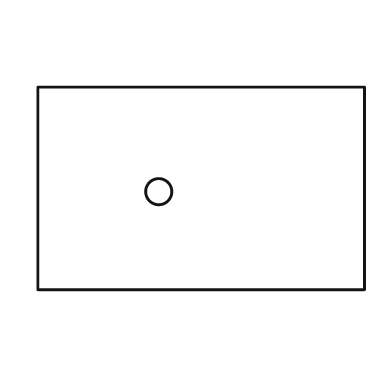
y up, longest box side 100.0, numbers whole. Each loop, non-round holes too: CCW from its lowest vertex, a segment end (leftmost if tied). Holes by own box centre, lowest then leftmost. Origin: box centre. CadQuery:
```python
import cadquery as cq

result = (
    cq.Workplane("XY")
    .moveTo(-50.0, -31.0)
    .lineTo(50.0, -31.0)
    .lineTo(50.0, 31.0)
    .lineTo(-50.0, 31.0)
    .close()
    .moveTo(-13.0, -1.0)
    .circle(4.0)
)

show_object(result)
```